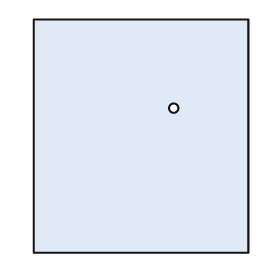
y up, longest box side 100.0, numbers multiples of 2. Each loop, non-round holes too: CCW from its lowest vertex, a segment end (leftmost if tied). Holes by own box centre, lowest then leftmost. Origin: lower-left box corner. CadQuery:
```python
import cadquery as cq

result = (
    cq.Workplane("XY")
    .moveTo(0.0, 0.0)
    .lineTo(92.0, 0.0)
    .lineTo(92.0, 100.0)
    .lineTo(0.0, 100.0)
    .close()
    .moveTo(60.0, 62.0)
    .circle(2.0)
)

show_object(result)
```